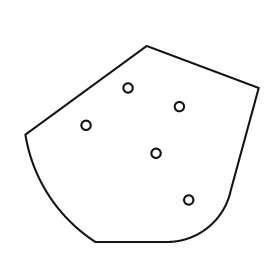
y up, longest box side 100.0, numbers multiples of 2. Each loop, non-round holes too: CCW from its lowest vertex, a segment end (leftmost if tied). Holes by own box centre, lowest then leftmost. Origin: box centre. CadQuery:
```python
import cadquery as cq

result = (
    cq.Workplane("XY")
    .moveTo(-20.0, -42.0)
    .lineTo(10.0, -42.0)
    .threePointArc((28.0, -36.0), (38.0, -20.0))
    .lineTo(50.0, 24.0)
    .lineTo(2.0, 42.0)
    .lineTo(-50.0, 4.0)
    .threePointArc((-40.0, -22.0), (-20.0, -42.0))
    .close()
    .moveTo(20.0, -24.0)
    .circle(2.0)
    .moveTo(6.0, -4.0)
    .circle(2.0)
    .moveTo(-24.0, 8.0)
    .circle(2.0)
    .moveTo(16.0, 16.0)
    .circle(2.0)
    .moveTo(-6.0, 24.0)
    .circle(2.0)
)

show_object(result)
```